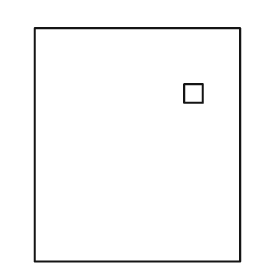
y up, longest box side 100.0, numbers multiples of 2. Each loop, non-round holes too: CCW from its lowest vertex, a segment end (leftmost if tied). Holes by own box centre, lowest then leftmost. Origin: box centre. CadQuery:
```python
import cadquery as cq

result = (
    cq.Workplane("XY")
    .moveTo(-44.0, -50.0)
    .lineTo(44.0, -50.0)
    .lineTo(44.0, 50.0)
    .lineTo(-44.0, 50.0)
    .close()
    .moveTo(20.0, 18.0)
    .lineTo(28.0, 18.0)
    .lineTo(28.0, 26.0)
    .lineTo(20.0, 26.0)
    .close()
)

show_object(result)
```